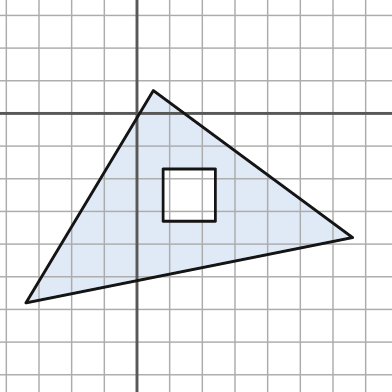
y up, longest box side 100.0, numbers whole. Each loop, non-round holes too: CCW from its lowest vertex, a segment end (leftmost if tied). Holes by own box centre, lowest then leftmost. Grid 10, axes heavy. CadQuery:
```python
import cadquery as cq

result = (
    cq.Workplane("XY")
    .moveTo(-34.0, -58.0)
    .lineTo(66.0, -38.0)
    .lineTo(5.0, 7.0)
    .close()
    .moveTo(8.0, -33.0)
    .lineTo(24.0, -33.0)
    .lineTo(24.0, -17.0)
    .lineTo(8.0, -17.0)
    .close()
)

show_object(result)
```